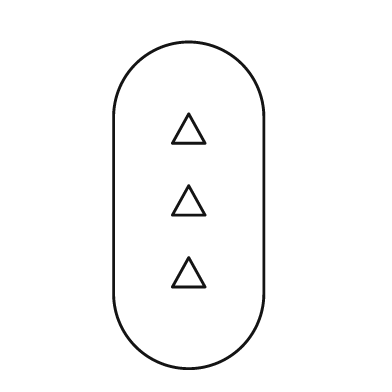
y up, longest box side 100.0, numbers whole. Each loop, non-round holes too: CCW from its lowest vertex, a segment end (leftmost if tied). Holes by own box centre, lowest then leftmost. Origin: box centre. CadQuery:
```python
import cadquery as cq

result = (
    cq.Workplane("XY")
    .moveTo(-23.0, -27.0)
    .threePointArc((0.0, -50.0), (23.0, -27.0))
    .lineTo(23.0, 27.0)
    .threePointArc((0.0, 50.0), (-23.0, 27.0))
    .close()
    .moveTo(-5.0, -25.0)
    .lineTo(5.0, -25.0)
    .lineTo(0.0, -16.0)
    .close()
    .moveTo(-5.0, -3.0)
    .lineTo(5.0, -3.0)
    .lineTo(0.0, 6.0)
    .close()
    .moveTo(-5.0, 19.0)
    .lineTo(5.0, 19.0)
    .lineTo(0.0, 28.0)
    .close()
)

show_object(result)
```